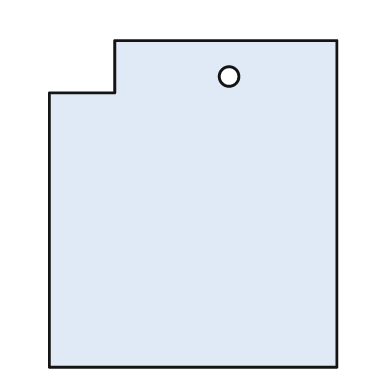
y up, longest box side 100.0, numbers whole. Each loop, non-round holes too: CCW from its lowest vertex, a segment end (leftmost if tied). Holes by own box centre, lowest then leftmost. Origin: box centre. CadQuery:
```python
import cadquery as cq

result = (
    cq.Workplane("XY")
    .moveTo(-44.0, -50.0)
    .lineTo(44.0, -50.0)
    .lineTo(44.0, 50.0)
    .lineTo(-24.0, 50.0)
    .lineTo(-24.0, 34.0)
    .lineTo(-44.0, 34.0)
    .close()
    .moveTo(11.0, 39.0)
    .circle(3.0)
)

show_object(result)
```